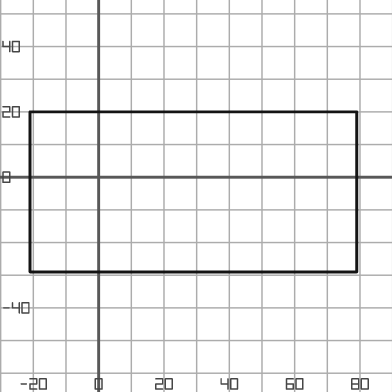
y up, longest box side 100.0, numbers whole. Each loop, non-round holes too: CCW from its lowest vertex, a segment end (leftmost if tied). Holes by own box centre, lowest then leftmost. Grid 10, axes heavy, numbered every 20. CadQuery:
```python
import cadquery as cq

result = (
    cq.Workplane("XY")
    .moveTo(-21.0, -29.0)
    .lineTo(79.0, -29.0)
    .lineTo(79.0, 20.0)
    .lineTo(-21.0, 20.0)
    .close()
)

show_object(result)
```